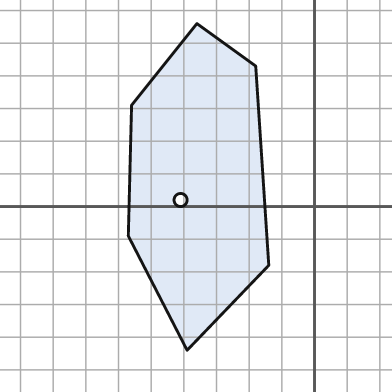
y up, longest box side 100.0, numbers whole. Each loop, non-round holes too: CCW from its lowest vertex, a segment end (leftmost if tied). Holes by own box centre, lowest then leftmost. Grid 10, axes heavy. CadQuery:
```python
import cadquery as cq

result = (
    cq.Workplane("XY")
    .moveTo(-39.0, -44.0)
    .lineTo(-14.0, -18.0)
    .lineTo(-18.0, 43.0)
    .lineTo(-36.0, 56.0)
    .lineTo(-56.0, 31.0)
    .lineTo(-57.0, -9.0)
    .close()
    .moveTo(-41.0, 2.0)
    .circle(2.0)
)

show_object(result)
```